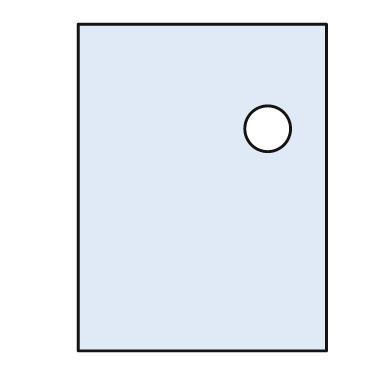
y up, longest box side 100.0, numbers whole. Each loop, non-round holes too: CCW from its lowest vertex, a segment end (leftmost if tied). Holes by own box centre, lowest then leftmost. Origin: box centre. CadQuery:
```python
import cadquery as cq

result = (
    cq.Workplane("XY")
    .moveTo(-38.0, -50.0)
    .lineTo(38.0, -50.0)
    .lineTo(38.0, 50.0)
    .lineTo(-38.0, 50.0)
    .close()
    .moveTo(20.0, 18.0)
    .circle(7.0)
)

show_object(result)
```